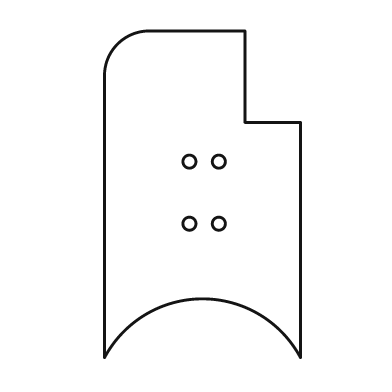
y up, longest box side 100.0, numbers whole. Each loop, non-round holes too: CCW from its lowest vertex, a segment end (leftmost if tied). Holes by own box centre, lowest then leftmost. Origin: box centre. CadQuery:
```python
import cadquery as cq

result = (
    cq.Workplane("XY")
    .moveTo(-30.0, -50.0)
    .threePointArc((0.0, -32.0), (30.0, -50.0))
    .lineTo(30.0, 22.0)
    .lineTo(13.0, 22.0)
    .lineTo(13.0, 50.0)
    .lineTo(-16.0, 50.0)
    .threePointArc((-26.0, 46.0), (-30.0, 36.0))
    .close()
    .moveTo(-4.0, -9.0)
    .circle(2.0)
    .moveTo(5.0, -9.0)
    .circle(2.0)
    .moveTo(-4.0, 10.0)
    .circle(2.0)
    .moveTo(5.0, 10.0)
    .circle(2.0)
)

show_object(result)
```